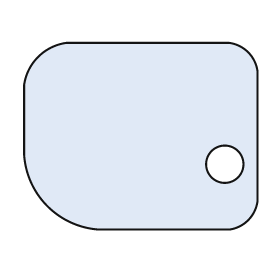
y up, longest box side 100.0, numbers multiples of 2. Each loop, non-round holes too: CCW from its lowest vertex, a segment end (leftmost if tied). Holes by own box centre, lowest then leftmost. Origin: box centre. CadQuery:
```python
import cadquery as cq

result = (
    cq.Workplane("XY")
    .moveTo(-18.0, -40.0)
    .lineTo(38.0, -40.0)
    .threePointArc((46.0, -36.0), (50.0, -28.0))
    .lineTo(50.0, 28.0)
    .threePointArc((46.0, 36.0), (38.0, 40.0))
    .lineTo(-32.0, 40.0)
    .threePointArc((-44.0, 34.0), (-50.0, 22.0))
    .lineTo(-50.0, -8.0)
    .threePointArc((-40.0, -30.0), (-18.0, -40.0))
    .close()
    .moveTo(36.0, -12.0)
    .circle(8.0)
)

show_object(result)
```